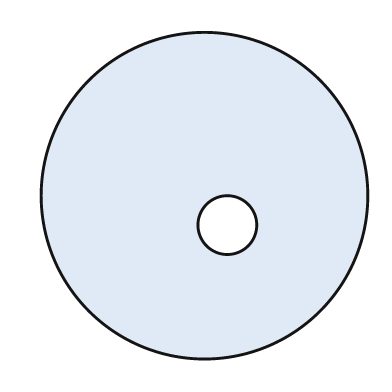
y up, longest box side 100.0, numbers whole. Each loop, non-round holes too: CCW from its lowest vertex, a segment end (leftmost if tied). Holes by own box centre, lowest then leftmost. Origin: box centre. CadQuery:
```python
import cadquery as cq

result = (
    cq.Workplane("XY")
    .moveTo(0.0, 0.0)
    .circle(50.0)
    .moveTo(7.0, -9.0)
    .circle(9.0)
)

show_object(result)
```